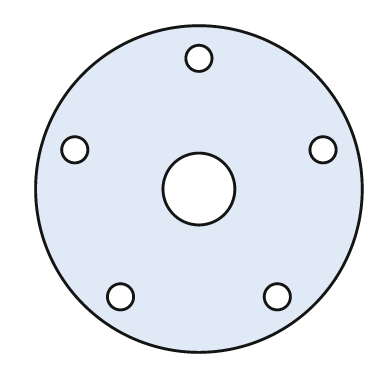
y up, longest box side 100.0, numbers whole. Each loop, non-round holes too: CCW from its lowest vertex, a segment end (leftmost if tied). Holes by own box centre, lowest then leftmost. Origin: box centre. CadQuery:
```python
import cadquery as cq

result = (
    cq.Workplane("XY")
    .moveTo(0.0, 0.0)
    .circle(50.0)
    .moveTo(-24.0, -33.0)
    .circle(4.0)
    .moveTo(24.0, -33.0)
    .circle(4.0)
    .moveTo(0.0, 0.0)
    .circle(11.0)
    .moveTo(-38.0, 12.0)
    .circle(4.0)
    .moveTo(38.0, 12.0)
    .circle(4.0)
    .moveTo(0.0, 40.0)
    .circle(4.0)
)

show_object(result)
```